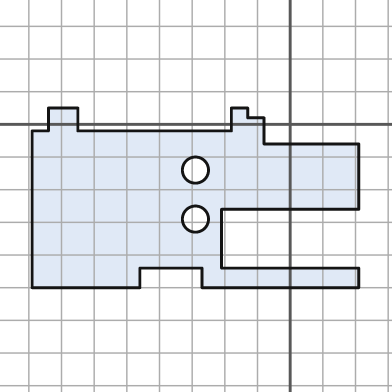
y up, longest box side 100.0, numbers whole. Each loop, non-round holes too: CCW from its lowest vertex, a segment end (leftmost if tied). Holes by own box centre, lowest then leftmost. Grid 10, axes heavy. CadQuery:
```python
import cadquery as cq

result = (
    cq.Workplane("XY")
    .moveTo(-79.0, -50.0)
    .lineTo(-46.0, -50.0)
    .lineTo(-46.0, -44.0)
    .lineTo(-27.0, -44.0)
    .lineTo(-27.0, -50.0)
    .lineTo(21.0, -50.0)
    .lineTo(21.0, -44.0)
    .lineTo(-21.0, -44.0)
    .lineTo(-21.0, -26.0)
    .lineTo(21.0, -26.0)
    .lineTo(21.0, -6.0)
    .lineTo(-8.0, -6.0)
    .lineTo(-8.0, 2.0)
    .lineTo(-13.0, 2.0)
    .lineTo(-13.0, 5.0)
    .lineTo(-18.0, 5.0)
    .lineTo(-18.0, -2.0)
    .lineTo(-65.0, -2.0)
    .lineTo(-65.0, 5.0)
    .lineTo(-74.0, 5.0)
    .lineTo(-74.0, -2.0)
    .lineTo(-79.0, -2.0)
    .close()
    .moveTo(-29.0, -29.0)
    .circle(4.0)
    .moveTo(-29.0, -14.0)
    .circle(4.0)
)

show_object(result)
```